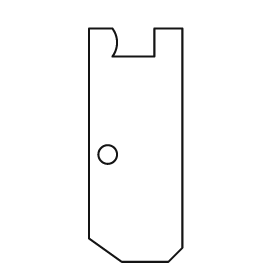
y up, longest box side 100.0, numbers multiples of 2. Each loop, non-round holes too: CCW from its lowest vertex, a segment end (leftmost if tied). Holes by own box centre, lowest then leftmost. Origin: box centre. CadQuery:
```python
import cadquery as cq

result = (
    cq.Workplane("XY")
    .moveTo(-6.0, -50.0)
    .lineTo(14.0, -50.0)
    .lineTo(20.0, -44.0)
    .lineTo(20.0, 50.0)
    .lineTo(8.0, 50.0)
    .lineTo(8.0, 38.0)
    .lineTo(-10.0, 38.0)
    .threePointArc((-8.0, 44.0), (-10.0, 50.0))
    .lineTo(-20.0, 50.0)
    .lineTo(-20.0, -40.0)
    .close()
    .moveTo(-12.0, -4.0)
    .circle(4.0)
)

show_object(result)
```